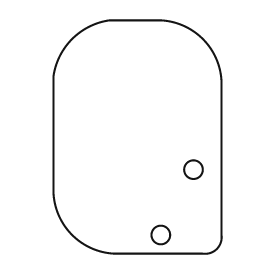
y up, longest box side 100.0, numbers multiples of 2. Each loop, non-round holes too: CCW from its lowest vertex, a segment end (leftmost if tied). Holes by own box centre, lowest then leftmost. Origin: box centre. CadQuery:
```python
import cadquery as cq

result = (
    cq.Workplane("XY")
    .moveTo(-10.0, -50.0)
    .lineTo(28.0, -50.0)
    .threePointArc((34.0, -48.0), (36.0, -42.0))
    .lineTo(36.0, 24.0)
    .threePointArc((28.0, 42.0), (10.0, 50.0))
    .lineTo(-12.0, 50.0)
    .threePointArc((-28.0, 42.0), (-36.0, 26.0))
    .lineTo(-36.0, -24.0)
    .threePointArc((-28.0, -42.0), (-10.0, -50.0))
    .close()
    .moveTo(10.0, -42.0)
    .circle(4.0)
    .moveTo(24.0, -14.0)
    .circle(4.0)
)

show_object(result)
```